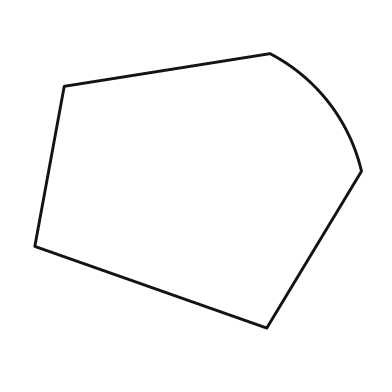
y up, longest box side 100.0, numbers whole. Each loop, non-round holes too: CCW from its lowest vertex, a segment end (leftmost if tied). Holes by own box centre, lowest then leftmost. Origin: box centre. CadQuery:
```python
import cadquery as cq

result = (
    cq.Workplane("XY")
    .moveTo(21.0, -42.0)
    .lineTo(50.0, 6.0)
    .threePointArc((40.0, 27.0), (22.0, 42.0))
    .lineTo(-41.0, 32.0)
    .lineTo(-50.0, -17.0)
    .close()
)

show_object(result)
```